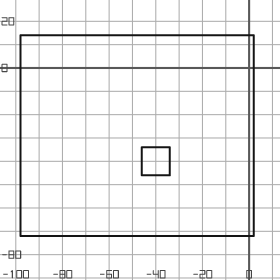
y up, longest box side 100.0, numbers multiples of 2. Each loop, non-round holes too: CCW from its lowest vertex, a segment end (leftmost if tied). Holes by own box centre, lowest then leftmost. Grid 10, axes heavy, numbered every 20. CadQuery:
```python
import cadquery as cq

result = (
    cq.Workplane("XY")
    .moveTo(-98.0, -72.0)
    .lineTo(2.0, -72.0)
    .lineTo(2.0, 14.0)
    .lineTo(-98.0, 14.0)
    .close()
    .moveTo(-46.0, -46.0)
    .lineTo(-34.0, -46.0)
    .lineTo(-34.0, -34.0)
    .lineTo(-46.0, -34.0)
    .close()
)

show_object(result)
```